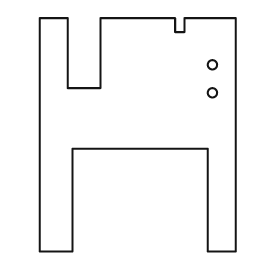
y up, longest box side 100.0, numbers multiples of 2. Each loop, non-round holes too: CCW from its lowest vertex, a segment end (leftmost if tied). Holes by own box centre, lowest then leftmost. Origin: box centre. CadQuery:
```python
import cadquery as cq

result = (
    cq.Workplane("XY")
    .moveTo(-42.0, -50.0)
    .lineTo(-28.0, -50.0)
    .lineTo(-28.0, -6.0)
    .lineTo(30.0, -6.0)
    .lineTo(30.0, -50.0)
    .lineTo(42.0, -50.0)
    .lineTo(42.0, 50.0)
    .lineTo(20.0, 50.0)
    .lineTo(20.0, 44.0)
    .lineTo(16.0, 44.0)
    .lineTo(16.0, 50.0)
    .lineTo(-16.0, 50.0)
    .lineTo(-16.0, 20.0)
    .lineTo(-30.0, 20.0)
    .lineTo(-30.0, 50.0)
    .lineTo(-42.0, 50.0)
    .close()
    .moveTo(32.0, 18.0)
    .circle(2.0)
    .moveTo(32.0, 30.0)
    .circle(2.0)
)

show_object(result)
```